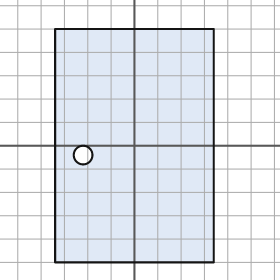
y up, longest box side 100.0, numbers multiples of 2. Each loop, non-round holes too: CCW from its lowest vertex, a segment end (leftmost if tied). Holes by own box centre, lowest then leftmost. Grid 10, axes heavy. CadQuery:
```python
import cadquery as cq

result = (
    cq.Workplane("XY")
    .moveTo(-34.0, -50.0)
    .lineTo(34.0, -50.0)
    .lineTo(34.0, 50.0)
    .lineTo(-34.0, 50.0)
    .close()
    .moveTo(-22.0, -4.0)
    .circle(4.0)
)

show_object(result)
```